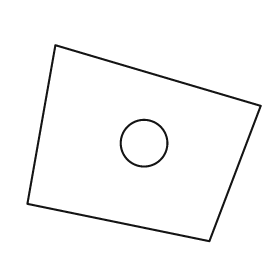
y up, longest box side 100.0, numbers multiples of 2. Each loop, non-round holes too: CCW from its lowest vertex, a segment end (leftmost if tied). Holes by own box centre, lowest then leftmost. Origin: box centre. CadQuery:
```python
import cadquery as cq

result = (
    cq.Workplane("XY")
    .moveTo(28.0, -42.0)
    .lineTo(50.0, 16.0)
    .lineTo(-38.0, 42.0)
    .lineTo(-50.0, -26.0)
    .close()
    .moveTo(0.0, 0.0)
    .circle(10.0)
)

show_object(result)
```